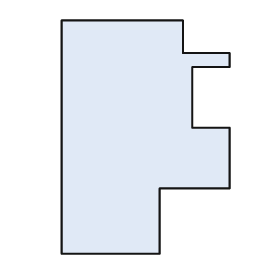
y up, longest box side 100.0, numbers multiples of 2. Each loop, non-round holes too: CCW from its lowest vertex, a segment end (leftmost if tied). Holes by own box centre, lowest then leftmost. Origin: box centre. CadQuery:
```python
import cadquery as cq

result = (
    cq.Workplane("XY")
    .moveTo(-36.0, -50.0)
    .lineTo(6.0, -50.0)
    .lineTo(6.0, -22.0)
    .lineTo(36.0, -22.0)
    .lineTo(36.0, 4.0)
    .lineTo(20.0, 4.0)
    .lineTo(20.0, 30.0)
    .lineTo(36.0, 30.0)
    .lineTo(36.0, 36.0)
    .lineTo(16.0, 36.0)
    .lineTo(16.0, 50.0)
    .lineTo(-36.0, 50.0)
    .close()
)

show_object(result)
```